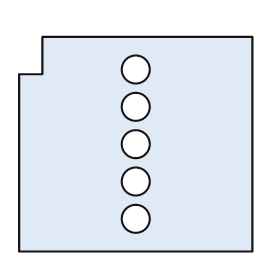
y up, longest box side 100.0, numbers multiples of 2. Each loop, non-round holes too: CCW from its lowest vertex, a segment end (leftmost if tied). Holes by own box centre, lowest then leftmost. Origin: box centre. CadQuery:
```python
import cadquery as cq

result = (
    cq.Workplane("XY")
    .moveTo(-50.0, -46.0)
    .lineTo(50.0, -46.0)
    .lineTo(50.0, 46.0)
    .lineTo(-40.0, 46.0)
    .lineTo(-40.0, 30.0)
    .lineTo(-50.0, 30.0)
    .close()
    .moveTo(0.0, -32.0)
    .circle(6.0)
    .moveTo(0.0, -16.0)
    .circle(6.0)
    .moveTo(0.0, 0.0)
    .circle(6.0)
    .moveTo(0.0, 16.0)
    .circle(6.0)
    .moveTo(0.0, 32.0)
    .circle(6.0)
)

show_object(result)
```